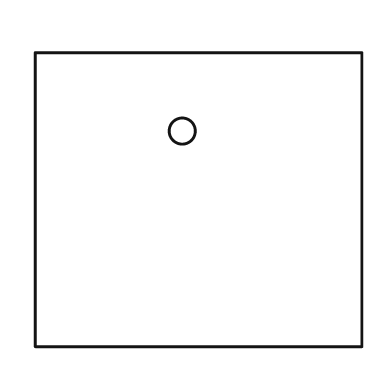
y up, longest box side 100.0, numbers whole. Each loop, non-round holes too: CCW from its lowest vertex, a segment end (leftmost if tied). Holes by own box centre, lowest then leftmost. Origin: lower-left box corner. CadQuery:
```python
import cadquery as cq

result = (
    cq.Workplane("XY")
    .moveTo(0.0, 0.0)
    .lineTo(100.0, 0.0)
    .lineTo(100.0, 90.0)
    .lineTo(0.0, 90.0)
    .close()
    .moveTo(45.0, 66.0)
    .circle(4.0)
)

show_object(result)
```